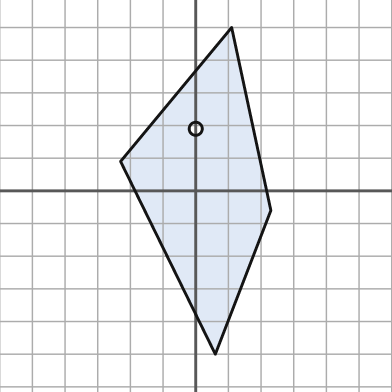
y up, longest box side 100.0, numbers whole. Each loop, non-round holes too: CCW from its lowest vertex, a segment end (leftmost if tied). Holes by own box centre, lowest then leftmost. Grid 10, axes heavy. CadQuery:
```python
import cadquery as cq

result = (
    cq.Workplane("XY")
    .moveTo(6.0, -50.0)
    .lineTo(23.0, -6.0)
    .lineTo(11.0, 50.0)
    .lineTo(-23.0, 9.0)
    .close()
    .moveTo(0.0, 19.0)
    .circle(2.0)
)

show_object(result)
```